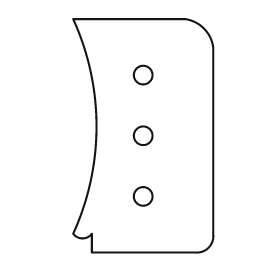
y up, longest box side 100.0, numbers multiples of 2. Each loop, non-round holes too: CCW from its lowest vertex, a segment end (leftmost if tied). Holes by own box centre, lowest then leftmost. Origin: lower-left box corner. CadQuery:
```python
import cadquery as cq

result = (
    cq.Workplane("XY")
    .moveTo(8.0, 0.0)
    .lineTo(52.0, 0.0)
    .threePointArc((58.0, 2.0), (60.0, 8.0))
    .lineTo(60.0, 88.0)
    .threePointArc((56.0, 96.0), (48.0, 100.0))
    .lineTo(0.0, 100.0)
    .threePointArc((10.0, 54.0), (0.0, 8.0))
    .threePointArc((4.0, 6.0), (8.0, 8.0))
    .close()
    .moveTo(30.0, 24.0)
    .circle(4.0)
    .moveTo(30.0, 50.0)
    .circle(4.0)
    .moveTo(30.0, 76.0)
    .circle(4.0)
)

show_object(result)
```